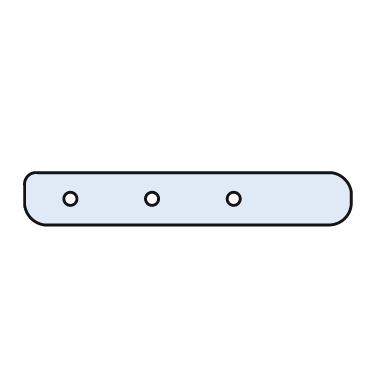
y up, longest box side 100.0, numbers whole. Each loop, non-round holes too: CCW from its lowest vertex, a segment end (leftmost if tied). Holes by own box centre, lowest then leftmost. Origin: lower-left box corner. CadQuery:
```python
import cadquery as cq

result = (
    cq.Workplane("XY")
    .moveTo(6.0, 0.0)
    .lineTo(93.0, 0.0)
    .threePointArc((98.0, 2.0), (100.0, 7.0))
    .lineTo(100.0, 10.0)
    .threePointArc((98.0, 14.0), (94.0, 16.0))
    .lineTo(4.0, 16.0)
    .threePointArc((1.0, 15.0), (0.0, 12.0))
    .lineTo(0.0, 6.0)
    .threePointArc((2.0, 2.0), (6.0, 0.0))
    .close()
    .moveTo(14.0, 8.0)
    .circle(2.0)
    .moveTo(39.0, 8.0)
    .circle(2.0)
    .moveTo(64.0, 8.0)
    .circle(2.0)
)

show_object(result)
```